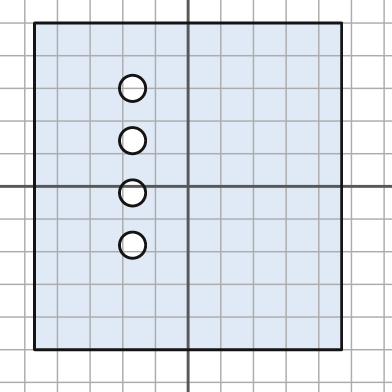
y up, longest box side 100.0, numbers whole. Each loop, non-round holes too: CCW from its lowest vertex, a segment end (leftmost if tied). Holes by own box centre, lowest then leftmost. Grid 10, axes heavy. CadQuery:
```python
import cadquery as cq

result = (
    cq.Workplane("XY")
    .moveTo(-47.0, -50.0)
    .lineTo(47.0, -50.0)
    .lineTo(47.0, 50.0)
    .lineTo(-47.0, 50.0)
    .close()
    .moveTo(-17.0, -18.0)
    .circle(4.0)
    .moveTo(-17.0, -2.0)
    .circle(4.0)
    .moveTo(-17.0, 14.0)
    .circle(4.0)
    .moveTo(-17.0, 30.0)
    .circle(4.0)
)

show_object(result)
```